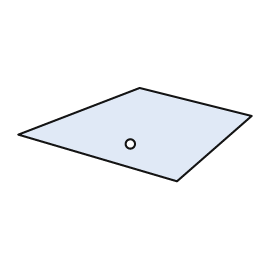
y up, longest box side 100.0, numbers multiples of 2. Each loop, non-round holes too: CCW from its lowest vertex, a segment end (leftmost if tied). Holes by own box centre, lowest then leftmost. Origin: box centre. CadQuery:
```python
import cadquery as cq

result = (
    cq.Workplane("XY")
    .moveTo(18.0, -20.0)
    .lineTo(50.0, 8.0)
    .lineTo(2.0, 20.0)
    .lineTo(-50.0, 0.0)
    .close()
    .moveTo(-2.0, -4.0)
    .circle(2.0)
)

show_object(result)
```